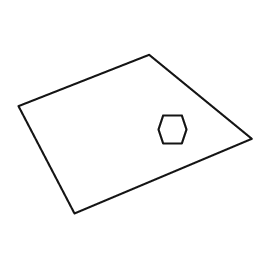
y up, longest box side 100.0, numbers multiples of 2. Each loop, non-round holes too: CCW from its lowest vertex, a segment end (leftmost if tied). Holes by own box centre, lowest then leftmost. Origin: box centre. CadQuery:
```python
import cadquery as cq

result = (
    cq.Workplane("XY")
    .moveTo(-26.0, -34.0)
    .lineTo(50.0, -2.0)
    .lineTo(6.0, 34.0)
    .lineTo(-50.0, 12.0)
    .close()
    .moveTo(12.0, -4.0)
    .lineTo(20.0, -4.0)
    .lineTo(22.0, 2.0)
    .lineTo(20.0, 8.0)
    .lineTo(12.0, 8.0)
    .lineTo(10.0, 2.0)
    .close()
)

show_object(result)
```